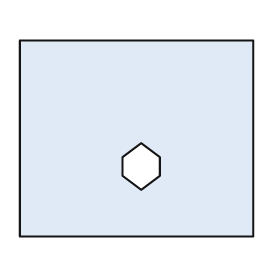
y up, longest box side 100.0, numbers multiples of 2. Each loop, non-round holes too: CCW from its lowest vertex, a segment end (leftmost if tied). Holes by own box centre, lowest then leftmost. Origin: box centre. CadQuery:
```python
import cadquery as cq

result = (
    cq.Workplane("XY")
    .moveTo(-50.0, -42.0)
    .lineTo(50.0, -42.0)
    .lineTo(50.0, 42.0)
    .lineTo(-50.0, 42.0)
    .close()
    .moveTo(2.0, -22.0)
    .lineTo(10.0, -16.0)
    .lineTo(10.0, -8.0)
    .lineTo(2.0, -2.0)
    .lineTo(-6.0, -8.0)
    .lineTo(-6.0, -16.0)
    .close()
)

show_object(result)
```